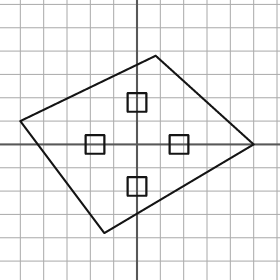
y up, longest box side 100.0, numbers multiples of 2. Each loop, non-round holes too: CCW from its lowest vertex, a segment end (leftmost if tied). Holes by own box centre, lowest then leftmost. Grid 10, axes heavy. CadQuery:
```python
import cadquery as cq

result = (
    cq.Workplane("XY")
    .moveTo(-14.0, -38.0)
    .lineTo(50.0, 0.0)
    .lineTo(8.0, 38.0)
    .lineTo(-50.0, 10.0)
    .close()
    .moveTo(-4.0, -22.0)
    .lineTo(4.0, -22.0)
    .lineTo(4.0, -14.0)
    .lineTo(-4.0, -14.0)
    .close()
    .moveTo(-22.0, -4.0)
    .lineTo(-14.0, -4.0)
    .lineTo(-14.0, 4.0)
    .lineTo(-22.0, 4.0)
    .close()
    .moveTo(14.0, -4.0)
    .lineTo(22.0, -4.0)
    .lineTo(22.0, 4.0)
    .lineTo(14.0, 4.0)
    .close()
    .moveTo(-4.0, 14.0)
    .lineTo(4.0, 14.0)
    .lineTo(4.0, 22.0)
    .lineTo(-4.0, 22.0)
    .close()
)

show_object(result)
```